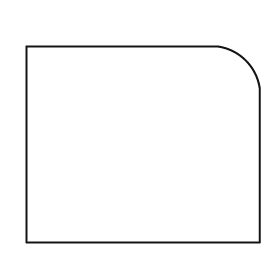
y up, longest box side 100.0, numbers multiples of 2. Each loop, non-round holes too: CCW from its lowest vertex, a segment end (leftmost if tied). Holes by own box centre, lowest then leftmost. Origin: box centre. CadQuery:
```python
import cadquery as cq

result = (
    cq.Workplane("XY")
    .moveTo(-50.0, -42.0)
    .lineTo(50.0, -42.0)
    .lineTo(50.0, 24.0)
    .threePointArc((44.0, 36.0), (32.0, 42.0))
    .lineTo(-50.0, 42.0)
    .close()
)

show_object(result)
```